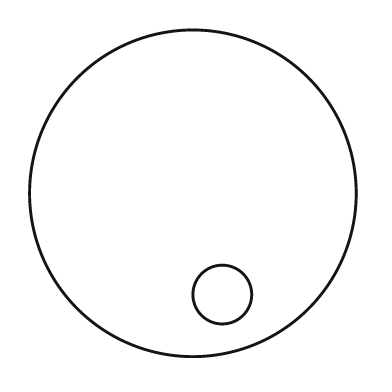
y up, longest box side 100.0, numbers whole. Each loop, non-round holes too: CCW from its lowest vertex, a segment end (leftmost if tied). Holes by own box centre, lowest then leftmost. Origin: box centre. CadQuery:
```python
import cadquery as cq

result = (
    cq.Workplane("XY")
    .moveTo(0.0, 0.0)
    .circle(50.0)
    .moveTo(9.0, -31.0)
    .circle(9.0)
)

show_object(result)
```